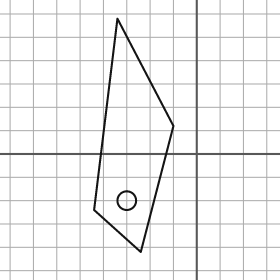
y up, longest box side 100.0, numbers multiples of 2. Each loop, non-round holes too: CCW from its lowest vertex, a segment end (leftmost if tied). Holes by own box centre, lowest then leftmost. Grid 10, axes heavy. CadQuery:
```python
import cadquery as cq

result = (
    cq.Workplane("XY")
    .moveTo(-24.0, -42.0)
    .lineTo(-10.0, 12.0)
    .lineTo(-34.0, 58.0)
    .lineTo(-44.0, -24.0)
    .close()
    .moveTo(-30.0, -20.0)
    .circle(4.0)
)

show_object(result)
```